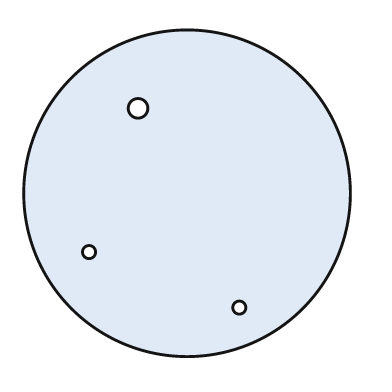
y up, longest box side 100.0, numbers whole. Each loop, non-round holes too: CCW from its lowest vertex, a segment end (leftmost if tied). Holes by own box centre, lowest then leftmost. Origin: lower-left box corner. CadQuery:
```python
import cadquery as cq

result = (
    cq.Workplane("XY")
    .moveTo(50.0, 50.0)
    .circle(50.0)
    .moveTo(66.0, 15.0)
    .circle(2.0)
    .moveTo(20.0, 32.0)
    .circle(2.0)
    .moveTo(35.0, 76.0)
    .circle(3.0)
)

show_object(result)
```